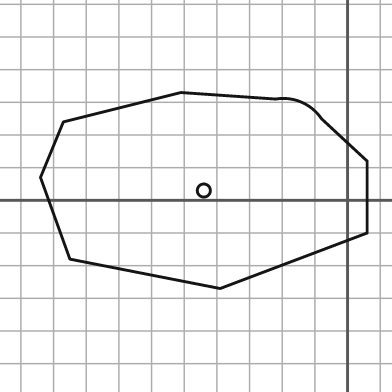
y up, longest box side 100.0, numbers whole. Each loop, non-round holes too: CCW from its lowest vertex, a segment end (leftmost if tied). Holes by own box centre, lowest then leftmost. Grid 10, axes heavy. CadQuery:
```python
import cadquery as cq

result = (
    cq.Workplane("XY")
    .moveTo(-39.0, -27.0)
    .lineTo(6.0, -10.0)
    .lineTo(6.0, 12.0)
    .lineTo(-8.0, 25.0)
    .threePointArc((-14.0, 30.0), (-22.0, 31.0))
    .lineTo(-51.0, 33.0)
    .lineTo(-87.0, 24.0)
    .lineTo(-94.0, 7.0)
    .lineTo(-85.0, -18.0)
    .close()
    .moveTo(-44.0, 3.0)
    .circle(2.0)
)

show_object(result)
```